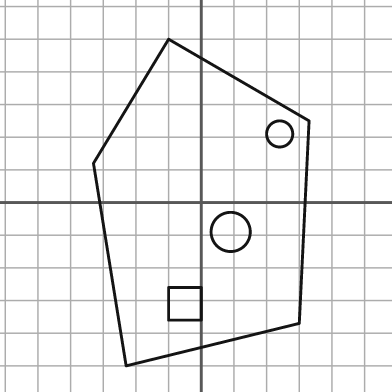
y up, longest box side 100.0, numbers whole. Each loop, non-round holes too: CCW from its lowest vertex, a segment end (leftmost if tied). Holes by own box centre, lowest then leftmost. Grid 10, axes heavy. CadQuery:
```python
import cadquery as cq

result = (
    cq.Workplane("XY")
    .moveTo(-23.0, -50.0)
    .lineTo(30.0, -37.0)
    .lineTo(33.0, 25.0)
    .lineTo(-10.0, 50.0)
    .lineTo(-33.0, 12.0)
    .close()
    .moveTo(-10.0, -36.0)
    .lineTo(0.0, -36.0)
    .lineTo(0.0, -26.0)
    .lineTo(-10.0, -26.0)
    .close()
    .moveTo(9.0, -9.0)
    .circle(6.0)
    .moveTo(24.0, 21.0)
    .circle(4.0)
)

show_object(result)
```